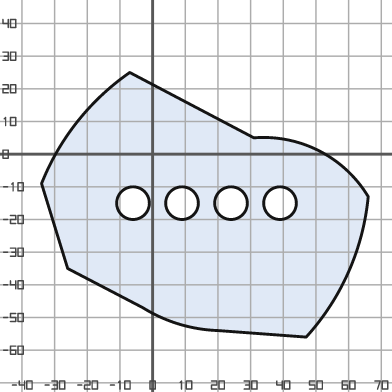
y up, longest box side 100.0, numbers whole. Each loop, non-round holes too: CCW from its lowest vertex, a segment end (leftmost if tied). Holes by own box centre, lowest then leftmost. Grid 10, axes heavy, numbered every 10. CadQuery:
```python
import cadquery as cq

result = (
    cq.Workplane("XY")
    .moveTo(47.0, -56.0)
    .threePointArc((60.0, -36.0), (66.0, -13.0))
    .threePointArc((51.0, 1.0), (31.0, 5.0))
    .lineTo(-7.0, 25.0)
    .threePointArc((-23.0, 10.0), (-34.0, -9.0))
    .lineTo(-26.0, -35.0)
    .lineTo(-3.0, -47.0)
    .threePointArc((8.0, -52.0), (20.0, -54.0))
    .close()
    .moveTo(-6.0, -15.0)
    .circle(5.0)
    .moveTo(9.0, -15.0)
    .circle(5.0)
    .moveTo(24.0, -15.0)
    .circle(5.0)
    .moveTo(39.0, -15.0)
    .circle(5.0)
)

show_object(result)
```